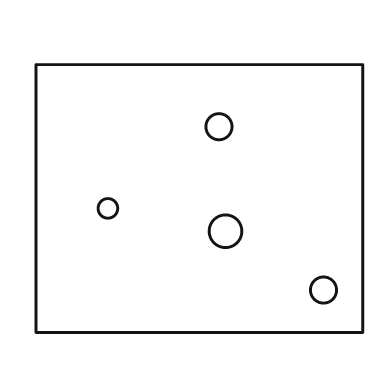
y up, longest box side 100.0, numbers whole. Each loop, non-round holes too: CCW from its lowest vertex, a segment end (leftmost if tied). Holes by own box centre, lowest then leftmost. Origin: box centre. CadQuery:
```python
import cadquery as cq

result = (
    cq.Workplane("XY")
    .moveTo(-50.0, -41.0)
    .lineTo(50.0, -41.0)
    .lineTo(50.0, 41.0)
    .lineTo(-50.0, 41.0)
    .close()
    .moveTo(38.0, -28.0)
    .circle(4.0)
    .moveTo(8.0, -10.0)
    .circle(5.0)
    .moveTo(-28.0, -3.0)
    .circle(3.0)
    .moveTo(6.0, 22.0)
    .circle(4.0)
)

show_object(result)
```